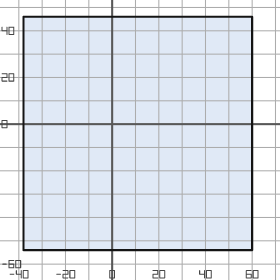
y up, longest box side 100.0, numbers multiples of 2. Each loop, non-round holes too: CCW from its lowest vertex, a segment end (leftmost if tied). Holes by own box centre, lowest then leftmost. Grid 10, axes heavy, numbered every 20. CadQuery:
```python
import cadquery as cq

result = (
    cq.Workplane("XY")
    .moveTo(-38.0, -54.0)
    .lineTo(60.0, -54.0)
    .lineTo(60.0, 46.0)
    .lineTo(-38.0, 46.0)
    .close()
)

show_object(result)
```